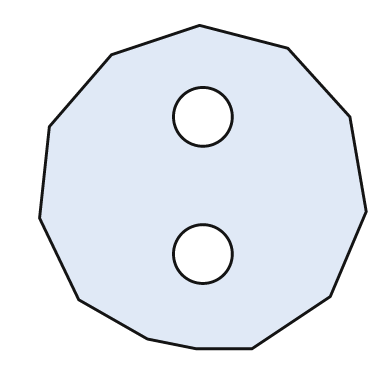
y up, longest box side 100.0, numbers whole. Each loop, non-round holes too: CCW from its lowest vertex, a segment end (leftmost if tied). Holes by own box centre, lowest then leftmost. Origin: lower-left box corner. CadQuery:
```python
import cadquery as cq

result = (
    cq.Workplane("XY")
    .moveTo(48.0, 0.0)
    .lineTo(65.0, 0.0)
    .lineTo(89.0, 16.0)
    .lineTo(100.0, 42.0)
    .lineTo(95.0, 71.0)
    .lineTo(76.0, 92.0)
    .lineTo(49.0, 99.0)
    .lineTo(22.0, 90.0)
    .lineTo(3.0, 68.0)
    .lineTo(0.0, 40.0)
    .lineTo(12.0, 15.0)
    .lineTo(33.0, 3.0)
    .close()
    .moveTo(50.0, 29.0)
    .circle(9.0)
    .moveTo(50.0, 71.0)
    .circle(9.0)
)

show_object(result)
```